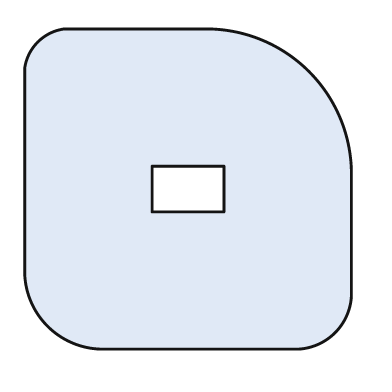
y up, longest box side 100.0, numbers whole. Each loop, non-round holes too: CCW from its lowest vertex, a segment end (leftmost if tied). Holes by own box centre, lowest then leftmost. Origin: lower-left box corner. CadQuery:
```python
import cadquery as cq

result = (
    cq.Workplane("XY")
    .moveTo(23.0, 0.0)
    .lineTo(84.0, 0.0)
    .threePointArc((95.0, 5.0), (100.0, 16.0))
    .lineTo(100.0, 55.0)
    .threePointArc((87.0, 85.0), (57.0, 98.0))
    .lineTo(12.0, 98.0)
    .threePointArc((4.0, 94.0), (0.0, 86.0))
    .lineTo(0.0, 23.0)
    .threePointArc((7.0, 7.0), (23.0, 0.0))
    .close()
    .moveTo(39.0, 42.0)
    .lineTo(61.0, 42.0)
    .lineTo(61.0, 56.0)
    .lineTo(39.0, 56.0)
    .close()
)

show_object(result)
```